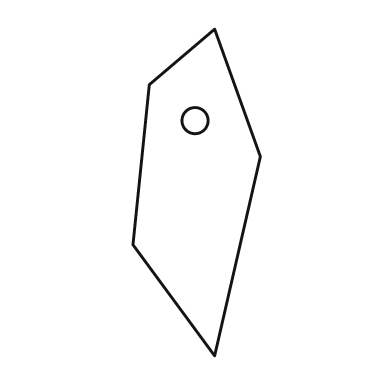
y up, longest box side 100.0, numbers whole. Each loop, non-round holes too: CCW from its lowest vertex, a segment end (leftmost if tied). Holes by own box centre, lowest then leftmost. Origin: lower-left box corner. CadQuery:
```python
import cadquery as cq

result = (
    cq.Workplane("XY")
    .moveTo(25.0, 0.0)
    .lineTo(39.0, 61.0)
    .lineTo(25.0, 100.0)
    .lineTo(5.0, 83.0)
    .lineTo(0.0, 34.0)
    .close()
    .moveTo(19.0, 72.0)
    .circle(4.0)
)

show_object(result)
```